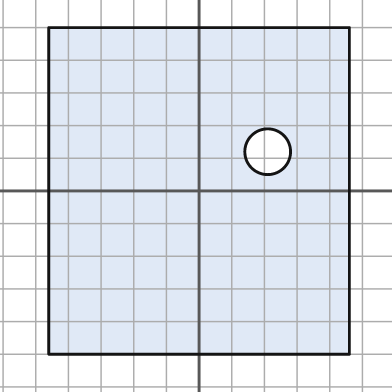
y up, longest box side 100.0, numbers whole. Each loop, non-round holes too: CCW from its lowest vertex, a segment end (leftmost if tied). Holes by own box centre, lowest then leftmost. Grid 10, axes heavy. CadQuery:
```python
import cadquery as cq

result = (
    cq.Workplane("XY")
    .moveTo(-46.0, -50.0)
    .lineTo(46.0, -50.0)
    .lineTo(46.0, 50.0)
    .lineTo(-46.0, 50.0)
    .close()
    .moveTo(21.0, 12.0)
    .circle(7.0)
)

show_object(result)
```